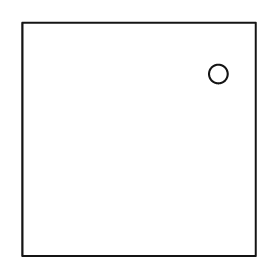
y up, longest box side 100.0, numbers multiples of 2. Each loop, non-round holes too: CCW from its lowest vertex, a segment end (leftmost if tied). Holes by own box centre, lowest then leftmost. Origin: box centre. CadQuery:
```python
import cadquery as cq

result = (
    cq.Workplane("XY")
    .moveTo(-50.0, -50.0)
    .lineTo(50.0, -50.0)
    .lineTo(50.0, 50.0)
    .lineTo(-50.0, 50.0)
    .close()
    .moveTo(34.0, 28.0)
    .circle(4.0)
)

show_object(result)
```